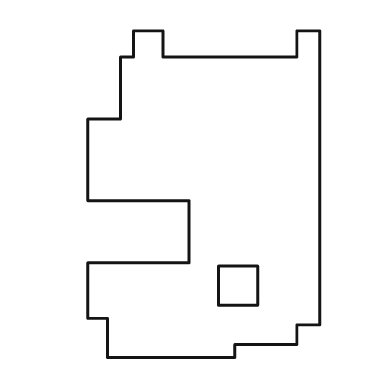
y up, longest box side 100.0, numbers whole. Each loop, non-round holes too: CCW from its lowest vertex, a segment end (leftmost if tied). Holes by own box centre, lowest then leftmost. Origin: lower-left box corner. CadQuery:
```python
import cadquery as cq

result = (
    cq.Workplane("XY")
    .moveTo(6.0, 0.0)
    .lineTo(45.0, 0.0)
    .lineTo(45.0, 4.0)
    .lineTo(64.0, 4.0)
    .lineTo(64.0, 10.0)
    .lineTo(71.0, 10.0)
    .lineTo(71.0, 100.0)
    .lineTo(64.0, 100.0)
    .lineTo(64.0, 92.0)
    .lineTo(23.0, 92.0)
    .lineTo(23.0, 100.0)
    .lineTo(14.0, 100.0)
    .lineTo(14.0, 92.0)
    .lineTo(10.0, 92.0)
    .lineTo(10.0, 73.0)
    .lineTo(0.0, 73.0)
    .lineTo(0.0, 48.0)
    .lineTo(31.0, 48.0)
    .lineTo(31.0, 29.0)
    .lineTo(0.0, 29.0)
    .lineTo(0.0, 12.0)
    .lineTo(6.0, 12.0)
    .close()
    .moveTo(40.0, 16.0)
    .lineTo(52.0, 16.0)
    .lineTo(52.0, 28.0)
    .lineTo(40.0, 28.0)
    .close()
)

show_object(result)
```